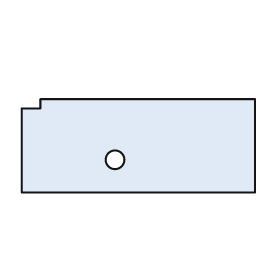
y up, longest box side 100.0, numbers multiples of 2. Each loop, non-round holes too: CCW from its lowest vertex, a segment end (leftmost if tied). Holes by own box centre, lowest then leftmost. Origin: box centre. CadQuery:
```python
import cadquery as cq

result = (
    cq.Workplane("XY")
    .moveTo(-50.0, -20.0)
    .lineTo(50.0, -20.0)
    .lineTo(50.0, 20.0)
    .lineTo(-42.0, 20.0)
    .lineTo(-42.0, 16.0)
    .lineTo(-50.0, 16.0)
    .close()
    .moveTo(-10.0, -6.0)
    .circle(4.0)
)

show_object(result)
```